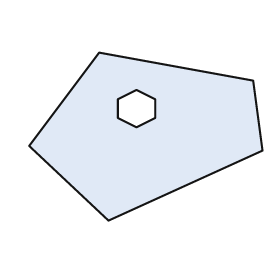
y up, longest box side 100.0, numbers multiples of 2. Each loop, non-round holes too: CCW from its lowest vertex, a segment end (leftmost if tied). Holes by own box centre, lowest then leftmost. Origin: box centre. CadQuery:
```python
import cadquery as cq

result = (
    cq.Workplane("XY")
    .moveTo(-16.0, -36.0)
    .lineTo(50.0, -6.0)
    .lineTo(46.0, 24.0)
    .lineTo(-20.0, 36.0)
    .lineTo(-50.0, -4.0)
    .close()
    .moveTo(-4.0, 4.0)
    .lineTo(4.0, 8.0)
    .lineTo(4.0, 16.0)
    .lineTo(-4.0, 20.0)
    .lineTo(-12.0, 16.0)
    .lineTo(-12.0, 8.0)
    .close()
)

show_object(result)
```